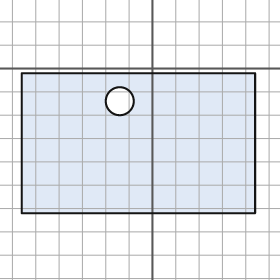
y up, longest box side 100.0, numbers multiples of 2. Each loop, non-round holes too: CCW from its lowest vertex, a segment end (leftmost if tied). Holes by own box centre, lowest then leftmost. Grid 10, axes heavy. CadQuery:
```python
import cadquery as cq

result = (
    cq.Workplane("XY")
    .moveTo(-56.0, -62.0)
    .lineTo(44.0, -62.0)
    .lineTo(44.0, -2.0)
    .lineTo(-56.0, -2.0)
    .close()
    .moveTo(-14.0, -14.0)
    .circle(6.0)
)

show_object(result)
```